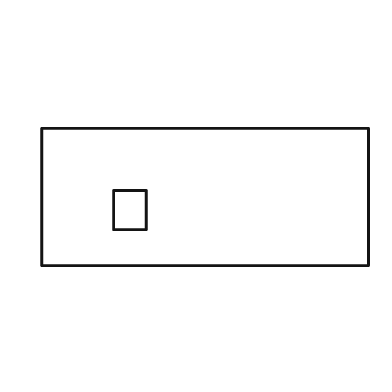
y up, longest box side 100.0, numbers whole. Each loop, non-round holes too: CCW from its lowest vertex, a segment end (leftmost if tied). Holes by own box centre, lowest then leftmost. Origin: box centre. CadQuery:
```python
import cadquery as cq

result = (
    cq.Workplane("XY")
    .moveTo(-50.0, -21.0)
    .lineTo(50.0, -21.0)
    .lineTo(50.0, 21.0)
    .lineTo(-50.0, 21.0)
    .close()
    .moveTo(-28.0, -10.0)
    .lineTo(-18.0, -10.0)
    .lineTo(-18.0, 2.0)
    .lineTo(-28.0, 2.0)
    .close()
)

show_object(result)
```